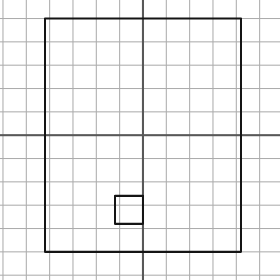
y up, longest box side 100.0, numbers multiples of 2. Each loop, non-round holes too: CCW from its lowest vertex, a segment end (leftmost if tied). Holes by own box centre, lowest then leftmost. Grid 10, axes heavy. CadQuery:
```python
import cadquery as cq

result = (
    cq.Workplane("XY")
    .moveTo(-42.0, -50.0)
    .lineTo(42.0, -50.0)
    .lineTo(42.0, 50.0)
    .lineTo(-42.0, 50.0)
    .close()
    .moveTo(-12.0, -38.0)
    .lineTo(0.0, -38.0)
    .lineTo(0.0, -26.0)
    .lineTo(-12.0, -26.0)
    .close()
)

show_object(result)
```